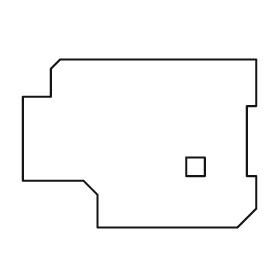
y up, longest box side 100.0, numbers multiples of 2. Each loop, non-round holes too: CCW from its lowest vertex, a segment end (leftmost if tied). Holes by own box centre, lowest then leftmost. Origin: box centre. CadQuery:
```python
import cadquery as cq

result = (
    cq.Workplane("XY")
    .moveTo(-18.0, -36.0)
    .lineTo(42.0, -36.0)
    .lineTo(50.0, -28.0)
    .lineTo(50.0, -14.0)
    .lineTo(46.0, -14.0)
    .lineTo(46.0, 16.0)
    .lineTo(50.0, 16.0)
    .lineTo(50.0, 36.0)
    .lineTo(-34.0, 36.0)
    .lineTo(-38.0, 32.0)
    .lineTo(-38.0, 20.0)
    .lineTo(-50.0, 20.0)
    .lineTo(-50.0, -16.0)
    .lineTo(-24.0, -16.0)
    .lineTo(-18.0, -22.0)
    .close()
    .moveTo(20.0, -14.0)
    .lineTo(28.0, -14.0)
    .lineTo(28.0, -6.0)
    .lineTo(20.0, -6.0)
    .close()
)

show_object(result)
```